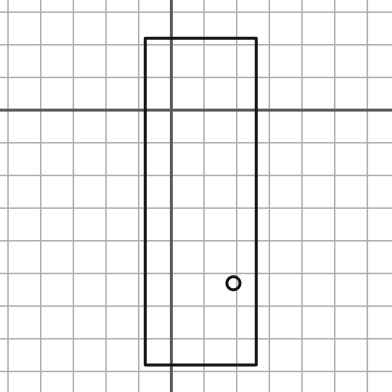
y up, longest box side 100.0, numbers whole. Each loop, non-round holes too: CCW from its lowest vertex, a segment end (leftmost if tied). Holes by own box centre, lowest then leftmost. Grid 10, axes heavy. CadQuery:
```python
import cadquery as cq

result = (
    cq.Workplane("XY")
    .moveTo(-8.0, -78.0)
    .lineTo(26.0, -78.0)
    .lineTo(26.0, 22.0)
    .lineTo(-8.0, 22.0)
    .close()
    .moveTo(19.0, -53.0)
    .circle(2.0)
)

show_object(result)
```